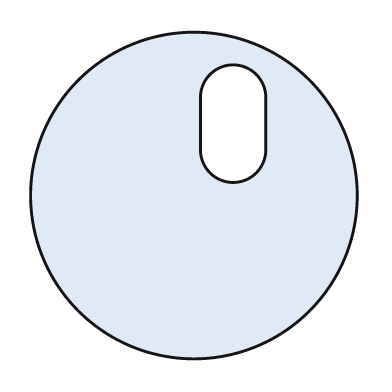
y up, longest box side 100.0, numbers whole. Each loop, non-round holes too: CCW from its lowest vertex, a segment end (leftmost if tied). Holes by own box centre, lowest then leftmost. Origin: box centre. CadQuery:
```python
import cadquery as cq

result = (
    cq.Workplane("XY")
    .moveTo(0.0, 0.0)
    .circle(50.0)
    .moveTo(2.0, 14.0)
    .threePointArc((12.0, 4.0), (22.0, 14.0))
    .lineTo(22.0, 30.0)
    .threePointArc((12.0, 40.0), (2.0, 30.0))
    .close()
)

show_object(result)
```